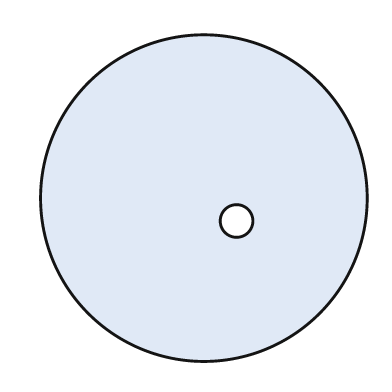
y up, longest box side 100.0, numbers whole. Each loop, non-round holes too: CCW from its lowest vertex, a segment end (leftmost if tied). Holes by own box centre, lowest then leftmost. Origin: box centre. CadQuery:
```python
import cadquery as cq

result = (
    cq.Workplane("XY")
    .moveTo(0.0, 0.0)
    .circle(50.0)
    .moveTo(10.0, -7.0)
    .circle(5.0)
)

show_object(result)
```